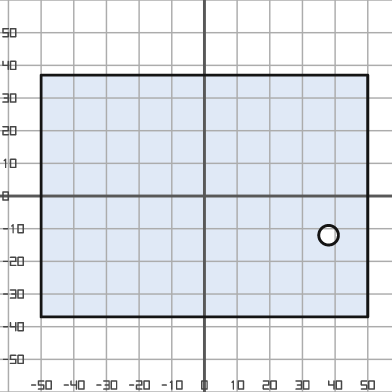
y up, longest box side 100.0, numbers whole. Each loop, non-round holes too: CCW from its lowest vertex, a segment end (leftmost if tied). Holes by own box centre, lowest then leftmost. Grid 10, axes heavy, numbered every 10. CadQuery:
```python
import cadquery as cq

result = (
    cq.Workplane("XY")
    .moveTo(-50.0, -37.0)
    .lineTo(50.0, -37.0)
    .lineTo(50.0, 37.0)
    .lineTo(-50.0, 37.0)
    .close()
    .moveTo(38.0, -12.0)
    .circle(3.0)
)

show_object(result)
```